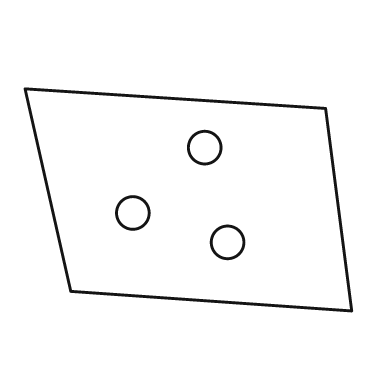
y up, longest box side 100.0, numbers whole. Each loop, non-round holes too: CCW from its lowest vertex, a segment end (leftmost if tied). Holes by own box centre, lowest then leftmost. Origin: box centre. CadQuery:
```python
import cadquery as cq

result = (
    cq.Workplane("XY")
    .moveTo(50.0, -34.0)
    .lineTo(42.0, 28.0)
    .lineTo(-50.0, 34.0)
    .lineTo(-36.0, -28.0)
    .close()
    .moveTo(12.0, -13.0)
    .circle(5.0)
    .moveTo(-17.0, -4.0)
    .circle(5.0)
    .moveTo(5.0, 16.0)
    .circle(5.0)
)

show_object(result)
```